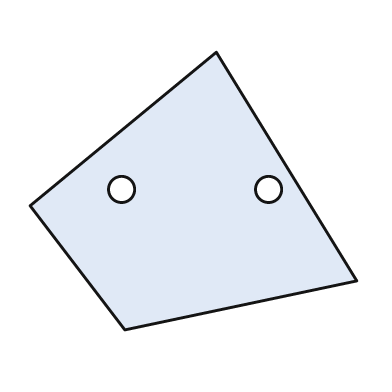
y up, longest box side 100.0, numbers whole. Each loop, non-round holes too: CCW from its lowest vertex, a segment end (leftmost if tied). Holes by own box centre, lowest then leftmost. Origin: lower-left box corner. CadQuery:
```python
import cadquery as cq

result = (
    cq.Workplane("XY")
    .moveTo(29.0, 0.0)
    .lineTo(100.0, 15.0)
    .lineTo(57.0, 85.0)
    .lineTo(0.0, 38.0)
    .close()
    .moveTo(28.0, 43.0)
    .circle(4.0)
    .moveTo(73.0, 43.0)
    .circle(4.0)
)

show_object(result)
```